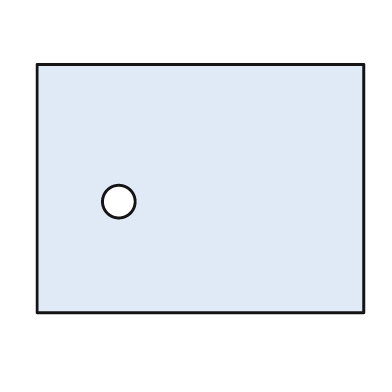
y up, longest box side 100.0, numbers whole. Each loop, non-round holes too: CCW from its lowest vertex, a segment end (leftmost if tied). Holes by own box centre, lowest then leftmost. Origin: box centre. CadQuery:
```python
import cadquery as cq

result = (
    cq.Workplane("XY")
    .moveTo(-50.0, -38.0)
    .lineTo(50.0, -38.0)
    .lineTo(50.0, 38.0)
    .lineTo(-50.0, 38.0)
    .close()
    .moveTo(-25.0, -4.0)
    .circle(5.0)
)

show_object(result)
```